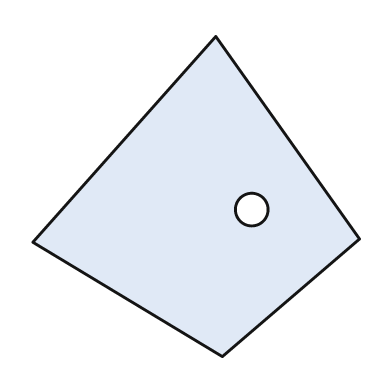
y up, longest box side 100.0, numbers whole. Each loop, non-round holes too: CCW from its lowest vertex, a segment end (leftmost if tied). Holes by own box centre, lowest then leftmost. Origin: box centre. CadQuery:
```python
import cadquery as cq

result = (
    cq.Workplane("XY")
    .moveTo(8.0, -49.0)
    .lineTo(50.0, -13.0)
    .lineTo(6.0, 49.0)
    .lineTo(-50.0, -14.0)
    .close()
    .moveTo(17.0, -4.0)
    .circle(5.0)
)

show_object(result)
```